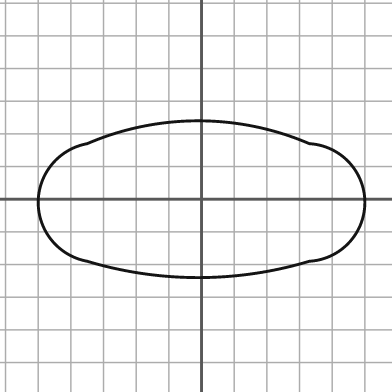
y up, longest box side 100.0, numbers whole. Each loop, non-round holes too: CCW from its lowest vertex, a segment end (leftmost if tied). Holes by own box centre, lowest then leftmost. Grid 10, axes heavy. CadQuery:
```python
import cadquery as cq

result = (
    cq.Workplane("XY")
    .moveTo(-35.0, -19.0)
    .threePointArc((-1.0, -24.0), (33.0, -19.0))
    .threePointArc((50.0, -1.0), (33.0, 17.0))
    .threePointArc((-1.0, 24.0), (-35.0, 17.0))
    .threePointArc((-50.0, -1.0), (-35.0, -19.0))
    .close()
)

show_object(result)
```